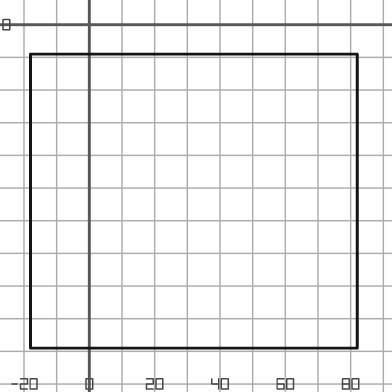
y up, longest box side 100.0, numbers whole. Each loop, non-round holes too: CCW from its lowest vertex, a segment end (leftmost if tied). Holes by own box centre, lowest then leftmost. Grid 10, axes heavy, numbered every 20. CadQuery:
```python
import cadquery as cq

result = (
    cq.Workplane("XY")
    .moveTo(-18.0, -99.0)
    .lineTo(82.0, -99.0)
    .lineTo(82.0, -9.0)
    .lineTo(-18.0, -9.0)
    .close()
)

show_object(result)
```